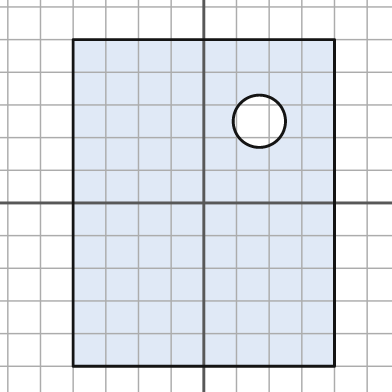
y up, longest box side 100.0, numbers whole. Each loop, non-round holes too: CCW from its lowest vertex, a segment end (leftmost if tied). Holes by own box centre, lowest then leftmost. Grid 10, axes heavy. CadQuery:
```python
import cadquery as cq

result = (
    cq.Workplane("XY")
    .moveTo(-40.0, -50.0)
    .lineTo(40.0, -50.0)
    .lineTo(40.0, 50.0)
    .lineTo(-40.0, 50.0)
    .close()
    .moveTo(17.0, 25.0)
    .circle(8.0)
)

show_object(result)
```